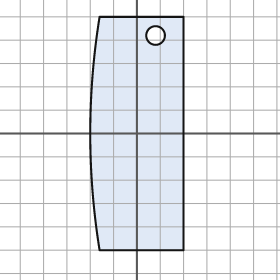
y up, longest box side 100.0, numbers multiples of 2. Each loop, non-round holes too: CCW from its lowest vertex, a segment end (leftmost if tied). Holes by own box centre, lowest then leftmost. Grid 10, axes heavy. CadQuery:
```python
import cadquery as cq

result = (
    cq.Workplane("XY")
    .moveTo(-16.0, -50.0)
    .lineTo(20.0, -50.0)
    .lineTo(20.0, 50.0)
    .lineTo(-16.0, 50.0)
    .threePointArc((-20.0, 0.0), (-16.0, -50.0))
    .close()
    .moveTo(8.0, 42.0)
    .circle(4.0)
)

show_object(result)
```